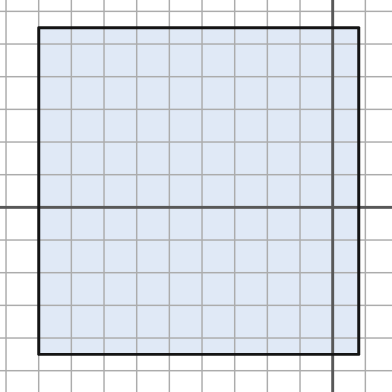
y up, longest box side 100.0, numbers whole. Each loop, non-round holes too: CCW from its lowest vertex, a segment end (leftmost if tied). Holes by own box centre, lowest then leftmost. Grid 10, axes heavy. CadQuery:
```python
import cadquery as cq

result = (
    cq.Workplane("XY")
    .moveTo(-90.0, -45.0)
    .lineTo(8.0, -45.0)
    .lineTo(8.0, 55.0)
    .lineTo(-90.0, 55.0)
    .close()
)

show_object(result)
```